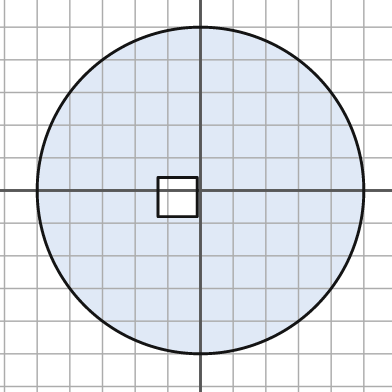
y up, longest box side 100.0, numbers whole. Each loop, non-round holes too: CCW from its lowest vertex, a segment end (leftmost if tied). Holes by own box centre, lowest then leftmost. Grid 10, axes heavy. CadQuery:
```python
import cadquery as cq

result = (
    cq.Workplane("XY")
    .moveTo(0.0, 0.0)
    .circle(50.0)
    .moveTo(-13.0, -8.0)
    .lineTo(-1.0, -8.0)
    .lineTo(-1.0, 4.0)
    .lineTo(-13.0, 4.0)
    .close()
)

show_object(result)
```